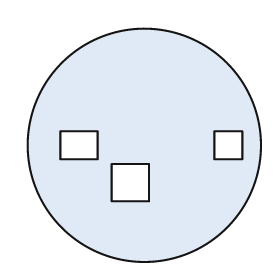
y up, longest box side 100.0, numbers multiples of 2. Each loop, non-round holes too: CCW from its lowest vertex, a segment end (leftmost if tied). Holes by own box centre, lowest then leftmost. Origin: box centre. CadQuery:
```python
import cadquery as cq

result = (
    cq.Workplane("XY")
    .moveTo(0.0, 0.0)
    .circle(50.0)
    .moveTo(-14.0, -24.0)
    .lineTo(2.0, -24.0)
    .lineTo(2.0, -8.0)
    .lineTo(-14.0, -8.0)
    .close()
    .moveTo(-36.0, -6.0)
    .lineTo(-20.0, -6.0)
    .lineTo(-20.0, 6.0)
    .lineTo(-36.0, 6.0)
    .close()
    .moveTo(30.0, -6.0)
    .lineTo(42.0, -6.0)
    .lineTo(42.0, 6.0)
    .lineTo(30.0, 6.0)
    .close()
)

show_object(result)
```